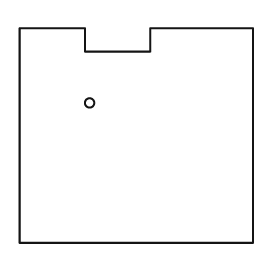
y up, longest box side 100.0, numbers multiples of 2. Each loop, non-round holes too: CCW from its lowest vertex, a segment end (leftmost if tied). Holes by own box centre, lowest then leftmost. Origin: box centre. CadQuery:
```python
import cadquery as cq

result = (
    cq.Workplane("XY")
    .moveTo(-50.0, -46.0)
    .lineTo(50.0, -46.0)
    .lineTo(50.0, 46.0)
    .lineTo(6.0, 46.0)
    .lineTo(6.0, 36.0)
    .lineTo(-22.0, 36.0)
    .lineTo(-22.0, 46.0)
    .lineTo(-50.0, 46.0)
    .close()
    .moveTo(-20.0, 14.0)
    .circle(2.0)
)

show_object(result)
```